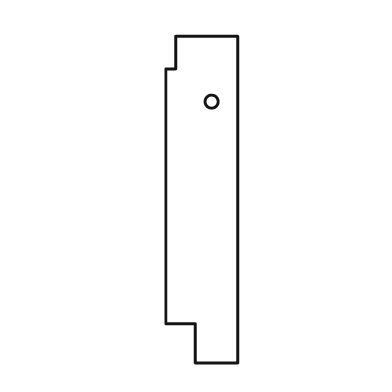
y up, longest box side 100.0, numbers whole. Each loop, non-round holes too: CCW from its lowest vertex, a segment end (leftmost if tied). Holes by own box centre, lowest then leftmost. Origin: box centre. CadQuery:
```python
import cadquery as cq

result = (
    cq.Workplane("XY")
    .moveTo(-2.0, -50.0)
    .lineTo(11.0, -50.0)
    .lineTo(11.0, 50.0)
    .lineTo(-8.0, 50.0)
    .lineTo(-8.0, 40.0)
    .lineTo(-11.0, 40.0)
    .lineTo(-11.0, -38.0)
    .lineTo(-2.0, -38.0)
    .close()
    .moveTo(3.0, 30.0)
    .circle(2.0)
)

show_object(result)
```